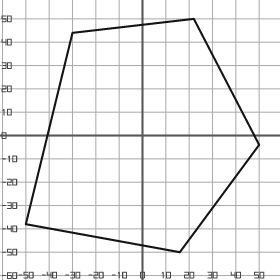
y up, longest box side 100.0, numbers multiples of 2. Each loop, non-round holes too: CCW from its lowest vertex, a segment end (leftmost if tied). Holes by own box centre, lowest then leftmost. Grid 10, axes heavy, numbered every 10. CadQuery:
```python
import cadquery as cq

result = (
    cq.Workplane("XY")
    .moveTo(16.0, -50.0)
    .lineTo(50.0, -4.0)
    .lineTo(22.0, 50.0)
    .lineTo(-30.0, 44.0)
    .lineTo(-50.0, -38.0)
    .close()
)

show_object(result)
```